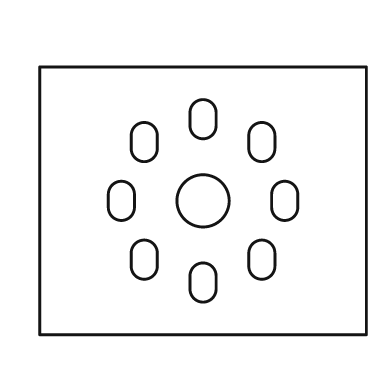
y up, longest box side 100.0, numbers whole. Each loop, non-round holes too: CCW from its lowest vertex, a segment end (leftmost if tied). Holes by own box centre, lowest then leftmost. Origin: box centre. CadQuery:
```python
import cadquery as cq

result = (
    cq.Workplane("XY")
    .moveTo(-50.0, -41.0)
    .lineTo(50.0, -41.0)
    .lineTo(50.0, 41.0)
    .lineTo(-50.0, 41.0)
    .close()
    .moveTo(-4.0, -27.0)
    .threePointArc((0.0, -31.0), (4.0, -27.0))
    .lineTo(4.0, -23.0)
    .threePointArc((0.0, -19.0), (-4.0, -23.0))
    .close()
    .moveTo(-22.0, -20.0)
    .threePointArc((-18.0, -24.0), (-14.0, -20.0))
    .lineTo(-14.0, -16.0)
    .threePointArc((-18.0, -12.0), (-22.0, -16.0))
    .close()
    .moveTo(14.0, -20.0)
    .threePointArc((18.0, -24.0), (22.0, -20.0))
    .lineTo(22.0, -16.0)
    .threePointArc((18.0, -12.0), (14.0, -16.0))
    .close()
    .moveTo(-29.0, -2.0)
    .threePointArc((-25.0, -6.0), (-21.0, -2.0))
    .lineTo(-21.0, 2.0)
    .threePointArc((-25.0, 6.0), (-29.0, 2.0))
    .close()
    .moveTo(0.0, 0.0)
    .circle(8.0)
    .moveTo(21.0, -2.0)
    .threePointArc((25.0, -6.0), (29.0, -2.0))
    .lineTo(29.0, 2.0)
    .threePointArc((25.0, 6.0), (21.0, 2.0))
    .close()
    .moveTo(-22.0, 16.0)
    .threePointArc((-18.0, 12.0), (-14.0, 16.0))
    .lineTo(-14.0, 20.0)
    .threePointArc((-18.0, 24.0), (-22.0, 20.0))
    .close()
    .moveTo(14.0, 16.0)
    .threePointArc((18.0, 12.0), (22.0, 16.0))
    .lineTo(22.0, 20.0)
    .threePointArc((18.0, 24.0), (14.0, 20.0))
    .close()
    .moveTo(-4.0, 23.0)
    .threePointArc((0.0, 19.0), (4.0, 23.0))
    .lineTo(4.0, 27.0)
    .threePointArc((0.0, 31.0), (-4.0, 27.0))
    .close()
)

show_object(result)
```